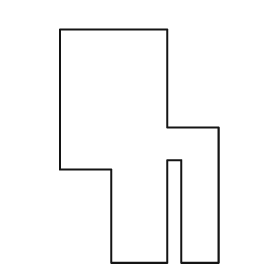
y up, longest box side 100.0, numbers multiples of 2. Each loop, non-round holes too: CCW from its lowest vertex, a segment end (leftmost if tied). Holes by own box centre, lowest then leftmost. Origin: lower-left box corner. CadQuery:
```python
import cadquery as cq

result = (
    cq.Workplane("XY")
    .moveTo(22.0, 0.0)
    .lineTo(46.0, 0.0)
    .lineTo(46.0, 44.0)
    .lineTo(52.0, 44.0)
    .lineTo(52.0, 0.0)
    .lineTo(68.0, 0.0)
    .lineTo(68.0, 58.0)
    .lineTo(46.0, 58.0)
    .lineTo(46.0, 100.0)
    .lineTo(0.0, 100.0)
    .lineTo(0.0, 40.0)
    .lineTo(22.0, 40.0)
    .close()
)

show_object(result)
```